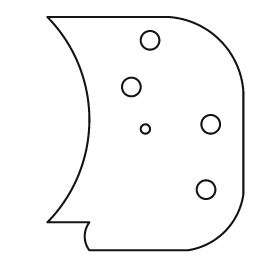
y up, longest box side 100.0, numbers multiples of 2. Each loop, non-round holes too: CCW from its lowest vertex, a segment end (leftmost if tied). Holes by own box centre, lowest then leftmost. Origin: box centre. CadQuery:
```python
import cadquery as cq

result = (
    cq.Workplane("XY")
    .moveTo(-24.0, -50.0)
    .lineTo(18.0, -50.0)
    .threePointArc((34.0, -42.0), (42.0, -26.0))
    .lineTo(42.0, 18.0)
    .threePointArc((32.0, 40.0), (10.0, 50.0))
    .lineTo(-42.0, 50.0)
    .threePointArc((-24.0, 6.0), (-42.0, -38.0))
    .lineTo(-24.0, -38.0)
    .threePointArc((-26.0, -44.0), (-24.0, -50.0))
    .close()
    .moveTo(26.0, -24.0)
    .circle(4.0)
    .moveTo(0.0, 2.0)
    .circle(2.0)
    .moveTo(28.0, 4.0)
    .circle(4.0)
    .moveTo(-6.0, 20.0)
    .circle(4.0)
    .moveTo(2.0, 40.0)
    .circle(4.0)
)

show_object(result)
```